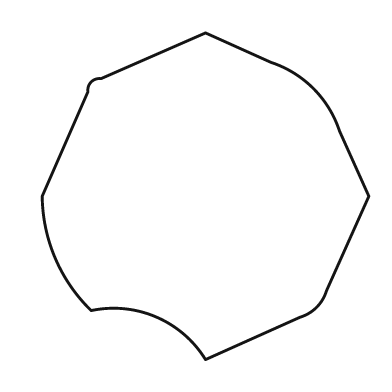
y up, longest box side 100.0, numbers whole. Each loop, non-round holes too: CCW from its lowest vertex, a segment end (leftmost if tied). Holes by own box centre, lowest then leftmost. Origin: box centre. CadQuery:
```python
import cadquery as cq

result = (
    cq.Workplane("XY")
    .moveTo(0.0, -50.0)
    .lineTo(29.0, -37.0)
    .threePointArc((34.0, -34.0), (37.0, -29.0))
    .lineTo(50.0, 0.0)
    .lineTo(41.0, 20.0)
    .threePointArc((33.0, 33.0), (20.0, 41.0))
    .lineTo(0.0, 50.0)
    .lineTo(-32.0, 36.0)
    .threePointArc((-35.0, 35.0), (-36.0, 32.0))
    .lineTo(-50.0, 0.0)
    .threePointArc((-46.0, -19.0), (-35.0, -35.0))
    .threePointArc((-15.0, -37.0), (0.0, -50.0))
    .close()
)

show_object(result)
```